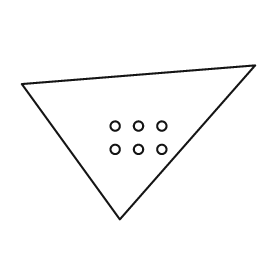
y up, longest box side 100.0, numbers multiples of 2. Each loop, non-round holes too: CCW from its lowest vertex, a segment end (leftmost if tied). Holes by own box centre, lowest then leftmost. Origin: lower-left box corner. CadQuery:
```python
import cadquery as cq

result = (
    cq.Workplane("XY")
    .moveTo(42.0, 0.0)
    .lineTo(100.0, 66.0)
    .lineTo(0.0, 58.0)
    .close()
    .moveTo(40.0, 30.0)
    .circle(2.0)
    .moveTo(50.0, 30.0)
    .circle(2.0)
    .moveTo(60.0, 30.0)
    .circle(2.0)
    .moveTo(40.0, 40.0)
    .circle(2.0)
    .moveTo(50.0, 40.0)
    .circle(2.0)
    .moveTo(60.0, 40.0)
    .circle(2.0)
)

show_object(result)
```